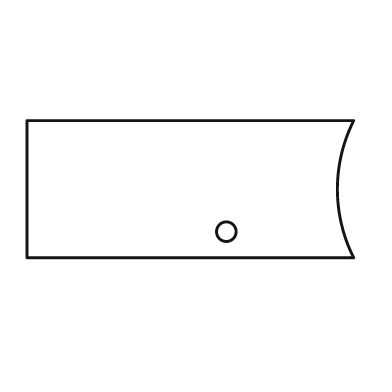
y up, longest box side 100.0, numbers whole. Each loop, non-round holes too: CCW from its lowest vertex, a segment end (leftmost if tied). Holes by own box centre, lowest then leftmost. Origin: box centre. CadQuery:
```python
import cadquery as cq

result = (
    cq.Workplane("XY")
    .moveTo(-50.0, -21.0)
    .lineTo(50.0, -21.0)
    .threePointArc((45.0, 0.0), (50.0, 21.0))
    .lineTo(-50.0, 21.0)
    .close()
    .moveTo(11.0, -13.0)
    .circle(3.0)
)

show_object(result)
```